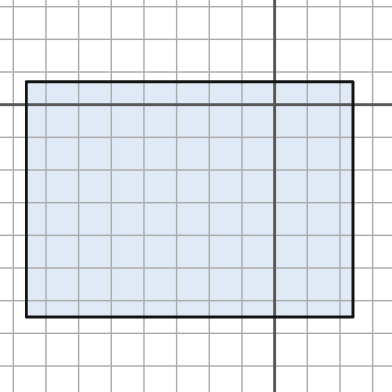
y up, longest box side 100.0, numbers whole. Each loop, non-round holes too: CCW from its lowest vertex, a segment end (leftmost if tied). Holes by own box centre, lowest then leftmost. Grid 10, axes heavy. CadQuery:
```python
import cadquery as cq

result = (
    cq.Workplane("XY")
    .moveTo(-76.0, -65.0)
    .lineTo(24.0, -65.0)
    .lineTo(24.0, 7.0)
    .lineTo(-76.0, 7.0)
    .close()
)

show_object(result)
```